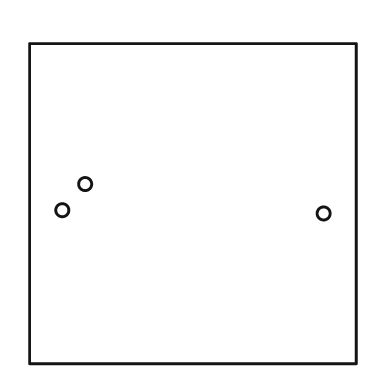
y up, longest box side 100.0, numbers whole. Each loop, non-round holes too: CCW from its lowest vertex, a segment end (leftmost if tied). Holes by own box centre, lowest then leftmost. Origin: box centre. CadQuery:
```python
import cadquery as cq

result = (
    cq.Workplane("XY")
    .moveTo(-50.0, -49.0)
    .lineTo(50.0, -49.0)
    .lineTo(50.0, 49.0)
    .lineTo(-50.0, 49.0)
    .close()
    .moveTo(40.0, -3.0)
    .circle(2.0)
    .moveTo(-40.0, -2.0)
    .circle(2.0)
    .moveTo(-33.0, 6.0)
    .circle(2.0)
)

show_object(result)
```